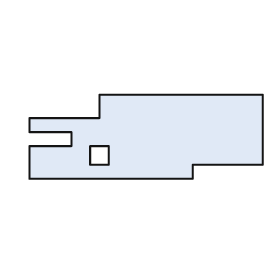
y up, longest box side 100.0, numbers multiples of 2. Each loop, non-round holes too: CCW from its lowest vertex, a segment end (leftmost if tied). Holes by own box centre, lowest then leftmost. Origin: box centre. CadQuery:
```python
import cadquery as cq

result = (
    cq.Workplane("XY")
    .moveTo(-50.0, -18.0)
    .lineTo(20.0, -18.0)
    .lineTo(20.0, -12.0)
    .lineTo(50.0, -12.0)
    .lineTo(50.0, 18.0)
    .lineTo(-20.0, 18.0)
    .lineTo(-20.0, 8.0)
    .lineTo(-50.0, 8.0)
    .lineTo(-50.0, 2.0)
    .lineTo(-32.0, 2.0)
    .lineTo(-32.0, -4.0)
    .lineTo(-50.0, -4.0)
    .close()
    .moveTo(-24.0, -12.0)
    .lineTo(-16.0, -12.0)
    .lineTo(-16.0, -4.0)
    .lineTo(-24.0, -4.0)
    .close()
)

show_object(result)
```